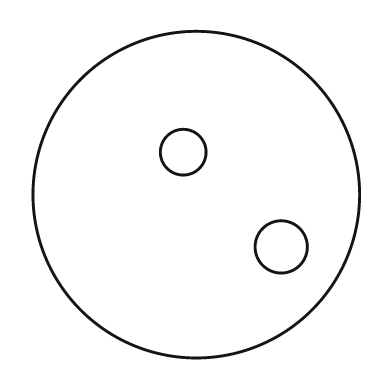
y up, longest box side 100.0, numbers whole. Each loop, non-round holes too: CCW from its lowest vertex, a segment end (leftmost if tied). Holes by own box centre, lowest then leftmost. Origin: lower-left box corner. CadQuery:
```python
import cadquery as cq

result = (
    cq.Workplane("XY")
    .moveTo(50.0, 50.0)
    .circle(50.0)
    .moveTo(76.0, 34.0)
    .circle(8.0)
    .moveTo(46.0, 63.0)
    .circle(7.0)
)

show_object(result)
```